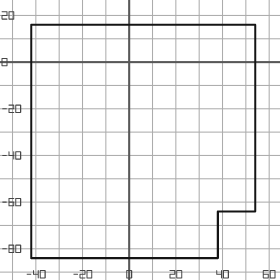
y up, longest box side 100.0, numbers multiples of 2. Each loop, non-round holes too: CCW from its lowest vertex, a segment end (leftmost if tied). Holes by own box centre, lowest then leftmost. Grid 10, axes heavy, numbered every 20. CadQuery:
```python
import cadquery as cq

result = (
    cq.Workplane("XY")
    .moveTo(-42.0, -84.0)
    .lineTo(38.0, -84.0)
    .lineTo(38.0, -64.0)
    .lineTo(54.0, -64.0)
    .lineTo(54.0, 16.0)
    .lineTo(-42.0, 16.0)
    .close()
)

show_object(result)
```